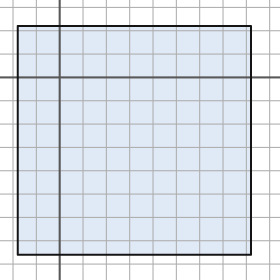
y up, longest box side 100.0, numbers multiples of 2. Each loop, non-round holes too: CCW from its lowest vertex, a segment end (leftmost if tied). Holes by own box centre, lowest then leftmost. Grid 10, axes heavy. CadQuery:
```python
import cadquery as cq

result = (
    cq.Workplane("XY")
    .moveTo(-18.0, -76.0)
    .lineTo(82.0, -76.0)
    .lineTo(82.0, 22.0)
    .lineTo(-18.0, 22.0)
    .close()
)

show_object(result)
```